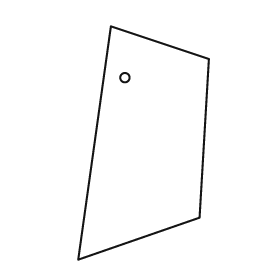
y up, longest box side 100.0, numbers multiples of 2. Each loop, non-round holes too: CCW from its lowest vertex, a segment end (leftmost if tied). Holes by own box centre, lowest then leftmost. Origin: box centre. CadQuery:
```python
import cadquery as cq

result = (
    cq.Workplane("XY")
    .moveTo(-28.0, -50.0)
    .lineTo(24.0, -32.0)
    .lineTo(28.0, 36.0)
    .lineTo(-14.0, 50.0)
    .close()
    .moveTo(-8.0, 28.0)
    .circle(2.0)
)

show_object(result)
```